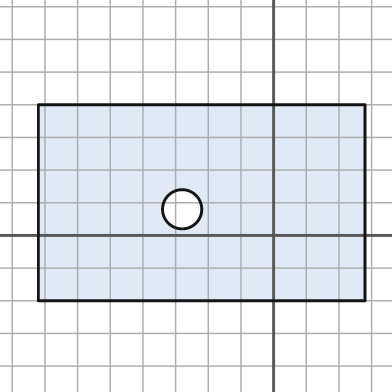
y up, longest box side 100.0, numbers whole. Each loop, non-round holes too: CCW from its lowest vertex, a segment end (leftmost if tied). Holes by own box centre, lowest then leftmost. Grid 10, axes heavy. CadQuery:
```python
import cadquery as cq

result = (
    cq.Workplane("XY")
    .moveTo(-72.0, -20.0)
    .lineTo(28.0, -20.0)
    .lineTo(28.0, 40.0)
    .lineTo(-72.0, 40.0)
    .close()
    .moveTo(-28.0, 8.0)
    .circle(6.0)
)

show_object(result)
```